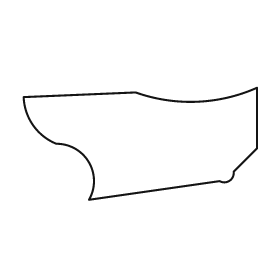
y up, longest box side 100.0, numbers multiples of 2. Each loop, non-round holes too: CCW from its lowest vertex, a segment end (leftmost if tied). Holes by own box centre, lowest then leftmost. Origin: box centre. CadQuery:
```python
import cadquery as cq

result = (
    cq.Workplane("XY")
    .moveTo(-22.0, -24.0)
    .lineTo(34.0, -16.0)
    .threePointArc((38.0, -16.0), (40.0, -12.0))
    .lineTo(50.0, -2.0)
    .lineTo(50.0, 24.0)
    .threePointArc((24.0, 18.0), (-2.0, 22.0))
    .lineTo(-50.0, 20.0)
    .threePointArc((-46.0, 8.0), (-36.0, 0.0))
    .threePointArc((-22.0, -8.0), (-22.0, -24.0))
    .close()
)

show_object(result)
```